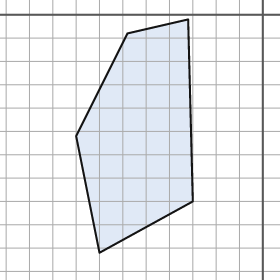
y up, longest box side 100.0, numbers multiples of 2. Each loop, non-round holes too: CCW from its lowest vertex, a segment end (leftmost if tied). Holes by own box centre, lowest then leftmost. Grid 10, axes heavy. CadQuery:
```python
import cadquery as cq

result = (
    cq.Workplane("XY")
    .moveTo(-70.0, -102.0)
    .lineTo(-30.0, -80.0)
    .lineTo(-32.0, -2.0)
    .lineTo(-58.0, -8.0)
    .lineTo(-80.0, -52.0)
    .close()
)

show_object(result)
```